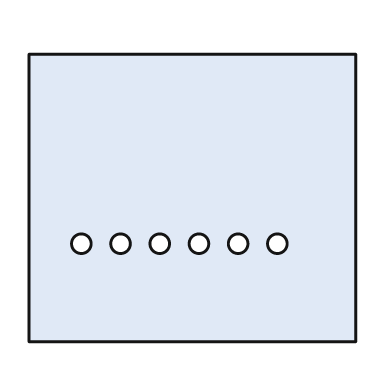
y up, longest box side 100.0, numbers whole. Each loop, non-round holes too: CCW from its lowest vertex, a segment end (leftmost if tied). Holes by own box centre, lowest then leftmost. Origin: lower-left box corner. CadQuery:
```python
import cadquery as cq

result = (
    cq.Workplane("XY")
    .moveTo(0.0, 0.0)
    .lineTo(100.0, 0.0)
    .lineTo(100.0, 88.0)
    .lineTo(0.0, 88.0)
    .close()
    .moveTo(16.0, 30.0)
    .circle(3.0)
    .moveTo(28.0, 30.0)
    .circle(3.0)
    .moveTo(40.0, 30.0)
    .circle(3.0)
    .moveTo(52.0, 30.0)
    .circle(3.0)
    .moveTo(64.0, 30.0)
    .circle(3.0)
    .moveTo(76.0, 30.0)
    .circle(3.0)
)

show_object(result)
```